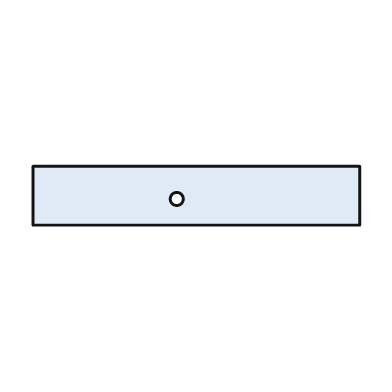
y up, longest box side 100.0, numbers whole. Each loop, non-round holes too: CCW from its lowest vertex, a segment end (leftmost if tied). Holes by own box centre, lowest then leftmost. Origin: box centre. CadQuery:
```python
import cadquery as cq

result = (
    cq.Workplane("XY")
    .moveTo(-50.0, -9.0)
    .lineTo(50.0, -9.0)
    .lineTo(50.0, 9.0)
    .lineTo(-50.0, 9.0)
    .close()
    .moveTo(-6.0, -1.0)
    .circle(2.0)
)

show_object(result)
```